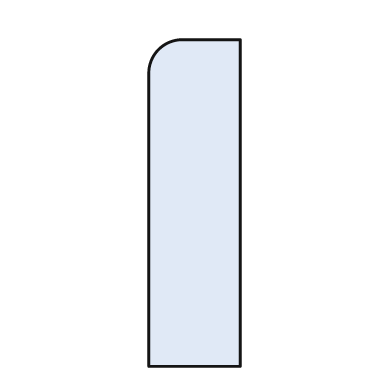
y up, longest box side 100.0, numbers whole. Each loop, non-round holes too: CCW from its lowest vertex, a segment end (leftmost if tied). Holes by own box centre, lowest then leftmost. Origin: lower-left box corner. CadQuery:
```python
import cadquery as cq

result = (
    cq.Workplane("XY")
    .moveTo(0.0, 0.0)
    .lineTo(28.0, 0.0)
    .lineTo(28.0, 100.0)
    .lineTo(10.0, 100.0)
    .threePointArc((3.0, 97.0), (0.0, 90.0))
    .close()
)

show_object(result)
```